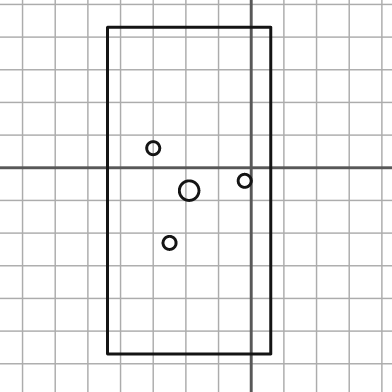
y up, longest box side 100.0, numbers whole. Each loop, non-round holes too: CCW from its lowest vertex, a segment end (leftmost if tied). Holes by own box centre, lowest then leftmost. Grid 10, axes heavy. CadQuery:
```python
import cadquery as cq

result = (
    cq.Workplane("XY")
    .moveTo(-44.0, -57.0)
    .lineTo(6.0, -57.0)
    .lineTo(6.0, 43.0)
    .lineTo(-44.0, 43.0)
    .close()
    .moveTo(-25.0, -23.0)
    .circle(2.0)
    .moveTo(-19.0, -7.0)
    .circle(3.0)
    .moveTo(-2.0, -4.0)
    .circle(2.0)
    .moveTo(-30.0, 6.0)
    .circle(2.0)
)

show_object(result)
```